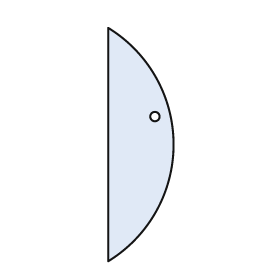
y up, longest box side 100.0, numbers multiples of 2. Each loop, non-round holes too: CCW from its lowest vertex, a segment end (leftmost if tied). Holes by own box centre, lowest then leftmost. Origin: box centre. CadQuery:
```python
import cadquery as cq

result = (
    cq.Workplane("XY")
    .moveTo(-14.0, -50.0)
    .threePointArc((14.0, 0.0), (-14.0, 50.0))
    .close()
    .moveTo(6.0, 12.0)
    .circle(2.0)
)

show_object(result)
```